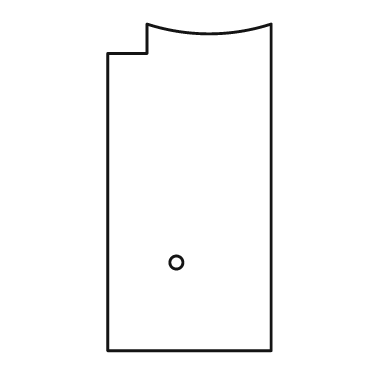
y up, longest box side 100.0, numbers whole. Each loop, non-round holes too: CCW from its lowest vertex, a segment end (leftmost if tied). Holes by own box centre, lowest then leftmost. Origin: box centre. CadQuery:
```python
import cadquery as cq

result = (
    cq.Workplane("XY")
    .moveTo(-25.0, -50.0)
    .lineTo(25.0, -50.0)
    .lineTo(25.0, 50.0)
    .threePointArc((6.0, 47.0), (-13.0, 50.0))
    .lineTo(-13.0, 41.0)
    .lineTo(-25.0, 41.0)
    .close()
    .moveTo(-4.0, -23.0)
    .circle(2.0)
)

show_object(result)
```